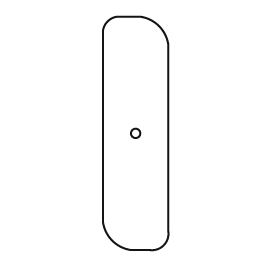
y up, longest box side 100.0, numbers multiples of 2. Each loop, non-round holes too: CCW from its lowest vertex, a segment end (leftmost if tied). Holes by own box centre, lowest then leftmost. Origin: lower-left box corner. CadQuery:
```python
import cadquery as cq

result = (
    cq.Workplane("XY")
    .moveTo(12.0, 0.0)
    .lineTo(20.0, 0.0)
    .threePointArc((26.0, 2.0), (28.0, 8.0))
    .lineTo(28.0, 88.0)
    .threePointArc((24.0, 96.0), (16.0, 100.0))
    .lineTo(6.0, 100.0)
    .threePointArc((2.0, 98.0), (0.0, 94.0))
    .lineTo(0.0, 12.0)
    .threePointArc((4.0, 4.0), (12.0, 0.0))
    .close()
    .moveTo(14.0, 50.0)
    .circle(2.0)
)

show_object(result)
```